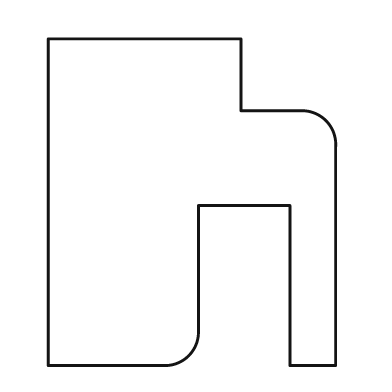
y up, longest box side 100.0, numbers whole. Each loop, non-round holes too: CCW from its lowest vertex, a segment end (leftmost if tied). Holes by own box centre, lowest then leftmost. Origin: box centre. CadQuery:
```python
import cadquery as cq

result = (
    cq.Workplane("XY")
    .moveTo(-44.0, -50.0)
    .lineTo(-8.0, -50.0)
    .threePointArc((-1.0, -47.0), (2.0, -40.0))
    .lineTo(2.0, -1.0)
    .lineTo(30.0, -1.0)
    .lineTo(30.0, -50.0)
    .lineTo(44.0, -50.0)
    .lineTo(44.0, 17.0)
    .threePointArc((41.0, 25.0), (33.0, 28.0))
    .lineTo(15.0, 28.0)
    .lineTo(15.0, 50.0)
    .lineTo(-44.0, 50.0)
    .close()
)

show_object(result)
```